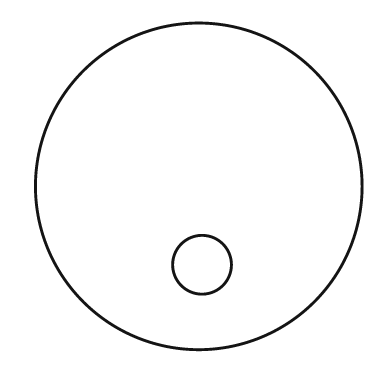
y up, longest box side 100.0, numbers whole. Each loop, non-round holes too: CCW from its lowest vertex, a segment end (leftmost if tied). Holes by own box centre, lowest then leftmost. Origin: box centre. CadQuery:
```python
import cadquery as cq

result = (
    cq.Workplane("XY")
    .moveTo(0.0, 0.0)
    .circle(50.0)
    .moveTo(1.0, -24.0)
    .circle(9.0)
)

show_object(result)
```